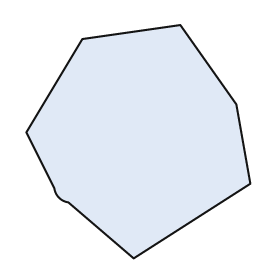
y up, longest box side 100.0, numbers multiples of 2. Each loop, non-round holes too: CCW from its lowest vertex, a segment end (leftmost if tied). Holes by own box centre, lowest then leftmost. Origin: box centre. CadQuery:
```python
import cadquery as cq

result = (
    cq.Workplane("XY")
    .moveTo(-2.0, -50.0)
    .lineTo(48.0, -18.0)
    .lineTo(42.0, 16.0)
    .lineTo(18.0, 50.0)
    .lineTo(-24.0, 44.0)
    .lineTo(-48.0, 4.0)
    .lineTo(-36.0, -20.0)
    .threePointArc((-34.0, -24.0), (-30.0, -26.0))
    .close()
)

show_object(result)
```